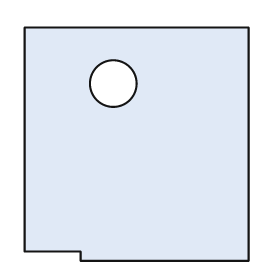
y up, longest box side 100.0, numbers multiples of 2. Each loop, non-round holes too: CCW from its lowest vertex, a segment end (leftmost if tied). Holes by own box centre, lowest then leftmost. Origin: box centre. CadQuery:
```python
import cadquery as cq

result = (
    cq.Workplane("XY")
    .moveTo(-24.0, -50.0)
    .lineTo(48.0, -50.0)
    .lineTo(48.0, 50.0)
    .lineTo(-48.0, 50.0)
    .lineTo(-48.0, -46.0)
    .lineTo(-24.0, -46.0)
    .close()
    .moveTo(-10.0, 26.0)
    .circle(10.0)
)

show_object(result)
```